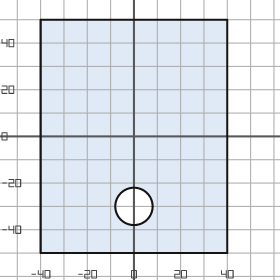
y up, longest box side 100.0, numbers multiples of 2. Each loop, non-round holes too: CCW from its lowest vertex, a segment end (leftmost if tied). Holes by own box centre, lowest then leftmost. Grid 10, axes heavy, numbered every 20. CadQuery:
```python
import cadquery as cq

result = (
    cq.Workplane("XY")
    .moveTo(-40.0, -50.0)
    .lineTo(40.0, -50.0)
    .lineTo(40.0, 50.0)
    .lineTo(-40.0, 50.0)
    .close()
    .moveTo(0.0, -30.0)
    .circle(8.0)
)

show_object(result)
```